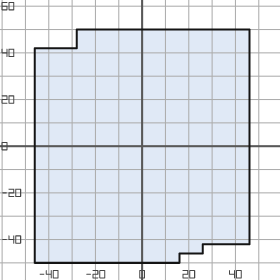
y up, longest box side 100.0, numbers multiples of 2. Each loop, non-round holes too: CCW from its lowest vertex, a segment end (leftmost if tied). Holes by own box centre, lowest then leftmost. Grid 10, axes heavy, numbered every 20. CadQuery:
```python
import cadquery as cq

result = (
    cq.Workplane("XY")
    .moveTo(-46.0, -50.0)
    .lineTo(16.0, -50.0)
    .lineTo(16.0, -46.0)
    .lineTo(26.0, -46.0)
    .lineTo(26.0, -42.0)
    .lineTo(46.0, -42.0)
    .lineTo(46.0, 50.0)
    .lineTo(-28.0, 50.0)
    .lineTo(-28.0, 42.0)
    .lineTo(-46.0, 42.0)
    .close()
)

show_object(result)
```